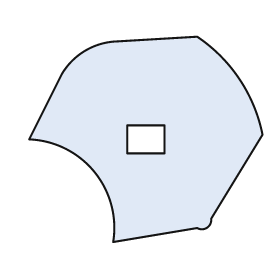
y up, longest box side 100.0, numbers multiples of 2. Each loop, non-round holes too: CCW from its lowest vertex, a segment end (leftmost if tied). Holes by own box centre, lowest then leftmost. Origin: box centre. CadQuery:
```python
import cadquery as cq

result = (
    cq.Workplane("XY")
    .moveTo(-14.0, -44.0)
    .lineTo(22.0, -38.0)
    .threePointArc((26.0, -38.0), (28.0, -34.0))
    .lineTo(50.0, 2.0)
    .threePointArc((40.0, 26.0), (22.0, 44.0))
    .lineTo(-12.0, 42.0)
    .threePointArc((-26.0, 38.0), (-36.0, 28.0))
    .lineTo(-50.0, 0.0)
    .threePointArc((-22.0, -14.0), (-14.0, -44.0))
    .close()
    .moveTo(-8.0, -6.0)
    .lineTo(8.0, -6.0)
    .lineTo(8.0, 6.0)
    .lineTo(-8.0, 6.0)
    .close()
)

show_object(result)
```